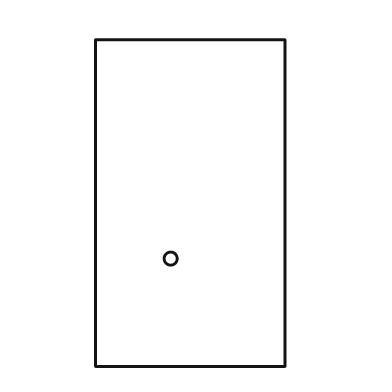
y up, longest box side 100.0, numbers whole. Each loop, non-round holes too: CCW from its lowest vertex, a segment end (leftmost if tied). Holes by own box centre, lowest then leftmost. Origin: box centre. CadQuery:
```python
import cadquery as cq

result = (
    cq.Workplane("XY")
    .moveTo(-29.0, -50.0)
    .lineTo(29.0, -50.0)
    .lineTo(29.0, 50.0)
    .lineTo(-29.0, 50.0)
    .close()
    .moveTo(-6.0, -17.0)
    .circle(2.0)
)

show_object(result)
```